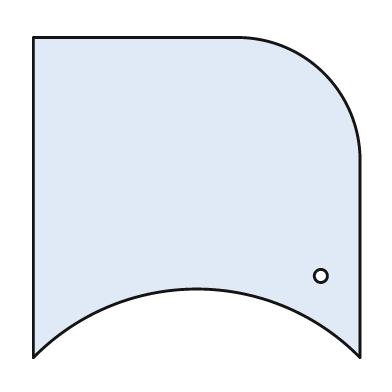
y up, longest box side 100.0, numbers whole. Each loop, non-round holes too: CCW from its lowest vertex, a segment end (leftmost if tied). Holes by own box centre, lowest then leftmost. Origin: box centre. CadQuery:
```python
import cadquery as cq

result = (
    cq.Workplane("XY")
    .moveTo(-50.0, -49.0)
    .threePointArc((0.0, -28.0), (50.0, -49.0))
    .lineTo(50.0, 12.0)
    .threePointArc((39.0, 38.0), (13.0, 49.0))
    .lineTo(-50.0, 49.0)
    .close()
    .moveTo(38.0, -24.0)
    .circle(2.0)
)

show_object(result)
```